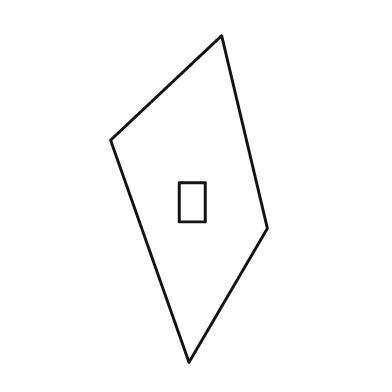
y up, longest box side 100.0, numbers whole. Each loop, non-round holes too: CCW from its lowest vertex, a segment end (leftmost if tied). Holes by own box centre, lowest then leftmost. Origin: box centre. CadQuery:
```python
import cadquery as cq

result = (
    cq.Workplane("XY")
    .moveTo(0.0, -50.0)
    .lineTo(24.0, -9.0)
    .lineTo(10.0, 50.0)
    .lineTo(-24.0, 18.0)
    .close()
    .moveTo(-3.0, -7.0)
    .lineTo(5.0, -7.0)
    .lineTo(5.0, 5.0)
    .lineTo(-3.0, 5.0)
    .close()
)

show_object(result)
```